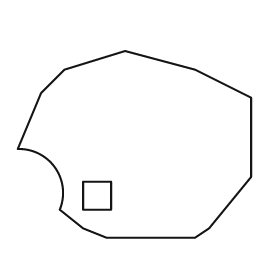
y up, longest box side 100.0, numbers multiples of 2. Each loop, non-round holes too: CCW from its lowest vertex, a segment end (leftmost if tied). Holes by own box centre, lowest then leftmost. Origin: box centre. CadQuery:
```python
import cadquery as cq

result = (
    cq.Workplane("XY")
    .moveTo(-12.0, -40.0)
    .lineTo(26.0, -40.0)
    .lineTo(32.0, -36.0)
    .lineTo(50.0, -14.0)
    .lineTo(50.0, 20.0)
    .lineTo(26.0, 32.0)
    .lineTo(-4.0, 40.0)
    .lineTo(-30.0, 32.0)
    .lineTo(-40.0, 22.0)
    .lineTo(-50.0, -2.0)
    .threePointArc((-34.0, -10.0), (-32.0, -28.0))
    .lineTo(-22.0, -36.0)
    .close()
    .moveTo(-22.0, -28.0)
    .lineTo(-10.0, -28.0)
    .lineTo(-10.0, -16.0)
    .lineTo(-22.0, -16.0)
    .close()
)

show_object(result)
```